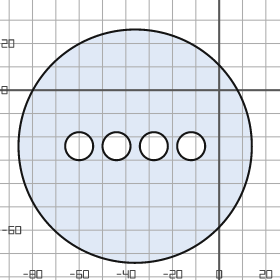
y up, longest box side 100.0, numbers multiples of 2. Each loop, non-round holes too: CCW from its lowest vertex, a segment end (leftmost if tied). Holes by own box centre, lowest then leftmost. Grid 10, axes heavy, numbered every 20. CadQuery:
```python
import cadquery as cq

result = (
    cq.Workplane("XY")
    .moveTo(-36.0, -24.0)
    .circle(50.0)
    .moveTo(-60.0, -24.0)
    .circle(6.0)
    .moveTo(-44.0, -24.0)
    .circle(6.0)
    .moveTo(-28.0, -24.0)
    .circle(6.0)
    .moveTo(-12.0, -24.0)
    .circle(6.0)
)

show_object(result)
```